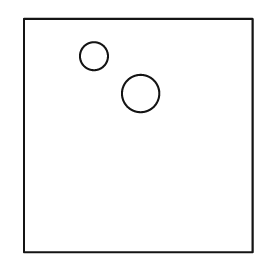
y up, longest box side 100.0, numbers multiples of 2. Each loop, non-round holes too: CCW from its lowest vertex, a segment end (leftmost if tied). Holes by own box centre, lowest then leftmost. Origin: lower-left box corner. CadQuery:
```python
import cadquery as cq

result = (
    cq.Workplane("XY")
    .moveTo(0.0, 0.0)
    .lineTo(98.0, 0.0)
    .lineTo(98.0, 100.0)
    .lineTo(0.0, 100.0)
    .close()
    .moveTo(50.0, 68.0)
    .circle(8.0)
    .moveTo(30.0, 84.0)
    .circle(6.0)
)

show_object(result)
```